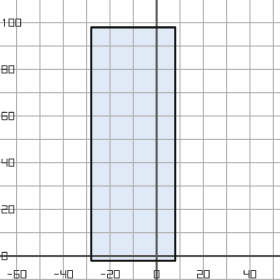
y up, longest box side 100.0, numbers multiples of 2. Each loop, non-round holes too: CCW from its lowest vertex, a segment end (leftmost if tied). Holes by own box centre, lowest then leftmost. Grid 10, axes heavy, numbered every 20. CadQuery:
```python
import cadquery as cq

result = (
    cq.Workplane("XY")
    .moveTo(-28.0, -2.0)
    .lineTo(8.0, -2.0)
    .lineTo(8.0, 98.0)
    .lineTo(-28.0, 98.0)
    .close()
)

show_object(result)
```